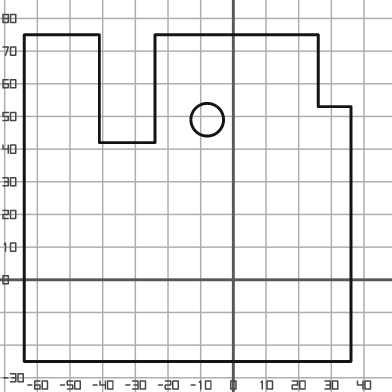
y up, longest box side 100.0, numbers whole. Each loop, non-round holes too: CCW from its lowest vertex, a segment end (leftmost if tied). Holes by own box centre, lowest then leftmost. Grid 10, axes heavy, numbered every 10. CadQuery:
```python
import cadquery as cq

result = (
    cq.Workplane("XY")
    .moveTo(-64.0, -25.0)
    .lineTo(36.0, -25.0)
    .lineTo(36.0, 53.0)
    .lineTo(26.0, 53.0)
    .lineTo(26.0, 75.0)
    .lineTo(-24.0, 75.0)
    .lineTo(-24.0, 42.0)
    .lineTo(-41.0, 42.0)
    .lineTo(-41.0, 75.0)
    .lineTo(-64.0, 75.0)
    .close()
    .moveTo(-8.0, 49.0)
    .circle(5.0)
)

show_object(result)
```